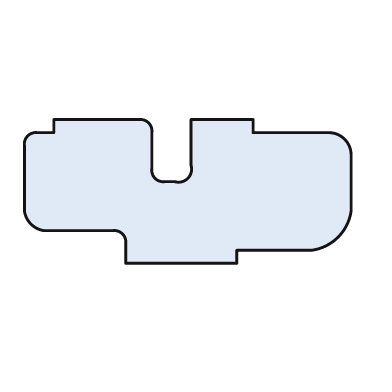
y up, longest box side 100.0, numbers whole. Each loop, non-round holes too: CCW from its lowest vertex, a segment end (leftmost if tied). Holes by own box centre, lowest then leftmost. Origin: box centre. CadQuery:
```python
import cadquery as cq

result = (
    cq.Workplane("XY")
    .moveTo(-19.0, -22.0)
    .lineTo(15.0, -22.0)
    .lineTo(15.0, -18.0)
    .lineTo(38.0, -18.0)
    .threePointArc((46.0, -14.0), (50.0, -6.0))
    .lineTo(50.0, 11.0)
    .threePointArc((48.0, 16.0), (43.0, 18.0))
    .lineTo(20.0, 18.0)
    .lineTo(20.0, 22.0)
    .lineTo(1.0, 22.0)
    .lineTo(1.0, 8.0)
    .threePointArc((0.0, 4.0), (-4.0, 3.0))
    .lineTo(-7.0, 3.0)
    .threePointArc((-10.0, 4.0), (-11.0, 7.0))
    .lineTo(-11.0, 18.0)
    .threePointArc((-12.0, 21.0), (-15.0, 22.0))
    .lineTo(-41.0, 22.0)
    .lineTo(-41.0, 18.0)
    .lineTo(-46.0, 18.0)
    .threePointArc((-49.0, 17.0), (-50.0, 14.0))
    .lineTo(-50.0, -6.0)
    .threePointArc((-48.0, -10.0), (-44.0, -12.0))
    .lineTo(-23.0, -12.0)
    .threePointArc((-20.0, -13.0), (-19.0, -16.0))
    .close()
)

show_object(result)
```